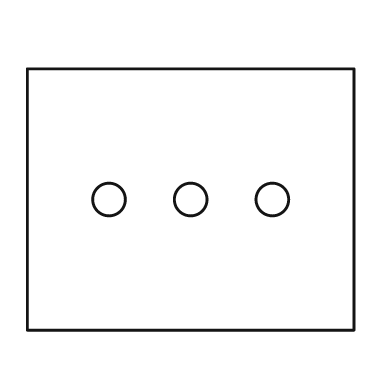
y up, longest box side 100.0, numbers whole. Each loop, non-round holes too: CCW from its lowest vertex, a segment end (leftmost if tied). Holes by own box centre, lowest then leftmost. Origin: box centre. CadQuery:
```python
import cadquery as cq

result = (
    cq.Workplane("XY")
    .moveTo(-50.0, -40.0)
    .lineTo(50.0, -40.0)
    .lineTo(50.0, 40.0)
    .lineTo(-50.0, 40.0)
    .close()
    .moveTo(-25.0, 0.0)
    .circle(5.0)
    .moveTo(0.0, 0.0)
    .circle(5.0)
    .moveTo(25.0, 0.0)
    .circle(5.0)
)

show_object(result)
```